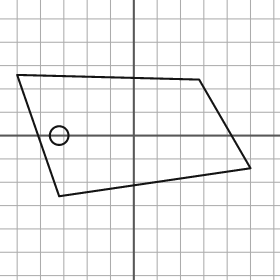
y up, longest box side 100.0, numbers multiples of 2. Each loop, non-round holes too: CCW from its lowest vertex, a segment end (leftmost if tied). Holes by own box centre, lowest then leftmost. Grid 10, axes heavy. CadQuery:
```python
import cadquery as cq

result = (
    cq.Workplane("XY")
    .moveTo(-32.0, -26.0)
    .lineTo(50.0, -14.0)
    .lineTo(28.0, 24.0)
    .lineTo(-50.0, 26.0)
    .close()
    .moveTo(-32.0, 0.0)
    .circle(4.0)
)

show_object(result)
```